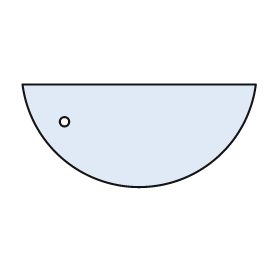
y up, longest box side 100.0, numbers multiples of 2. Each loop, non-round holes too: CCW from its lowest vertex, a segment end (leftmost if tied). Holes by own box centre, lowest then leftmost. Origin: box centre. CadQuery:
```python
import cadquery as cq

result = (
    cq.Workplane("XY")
    .moveTo(-50.0, 22.0)
    .threePointArc((0.0, -22.0), (50.0, 22.0))
    .close()
    .moveTo(-32.0, 6.0)
    .circle(2.0)
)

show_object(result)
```